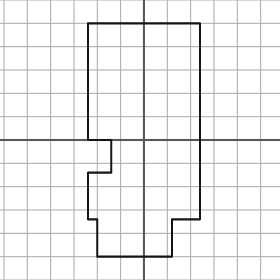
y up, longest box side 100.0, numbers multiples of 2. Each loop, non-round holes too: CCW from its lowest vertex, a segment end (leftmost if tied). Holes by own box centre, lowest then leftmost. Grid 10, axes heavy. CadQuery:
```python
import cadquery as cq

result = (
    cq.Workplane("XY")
    .moveTo(-20.0, -50.0)
    .lineTo(12.0, -50.0)
    .lineTo(12.0, -34.0)
    .lineTo(24.0, -34.0)
    .lineTo(24.0, 50.0)
    .lineTo(-24.0, 50.0)
    .lineTo(-24.0, 0.0)
    .lineTo(-14.0, 0.0)
    .lineTo(-14.0, -14.0)
    .lineTo(-24.0, -14.0)
    .lineTo(-24.0, -34.0)
    .lineTo(-20.0, -34.0)
    .close()
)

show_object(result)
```